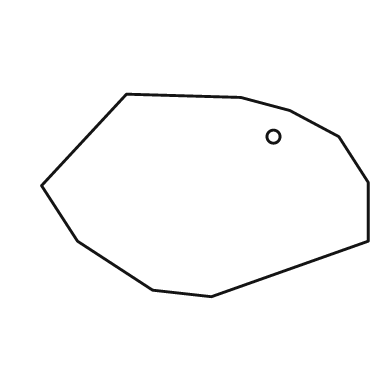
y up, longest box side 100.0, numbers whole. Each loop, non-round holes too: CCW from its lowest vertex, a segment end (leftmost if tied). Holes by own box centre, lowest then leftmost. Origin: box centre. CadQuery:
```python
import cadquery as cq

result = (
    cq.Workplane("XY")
    .moveTo(2.0, -31.0)
    .lineTo(50.0, -14.0)
    .lineTo(50.0, 4.0)
    .lineTo(41.0, 18.0)
    .lineTo(26.0, 26.0)
    .lineTo(11.0, 30.0)
    .lineTo(-24.0, 31.0)
    .lineTo(-50.0, 3.0)
    .lineTo(-39.0, -14.0)
    .lineTo(-16.0, -29.0)
    .close()
    .moveTo(21.0, 18.0)
    .circle(2.0)
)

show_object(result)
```